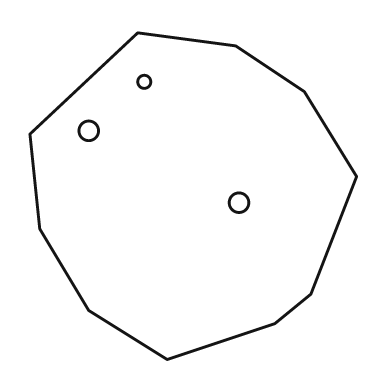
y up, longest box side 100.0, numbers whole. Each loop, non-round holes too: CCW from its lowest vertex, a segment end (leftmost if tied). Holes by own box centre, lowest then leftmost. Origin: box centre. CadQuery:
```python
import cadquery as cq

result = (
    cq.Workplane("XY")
    .moveTo(-8.0, -50.0)
    .lineTo(25.0, -39.0)
    .lineTo(36.0, -30.0)
    .lineTo(50.0, 6.0)
    .lineTo(34.0, 32.0)
    .lineTo(13.0, 46.0)
    .lineTo(-17.0, 50.0)
    .lineTo(-50.0, 19.0)
    .lineTo(-47.0, -10.0)
    .lineTo(-32.0, -35.0)
    .close()
    .moveTo(14.0, -2.0)
    .circle(3.0)
    .moveTo(-32.0, 20.0)
    .circle(3.0)
    .moveTo(-15.0, 35.0)
    .circle(2.0)
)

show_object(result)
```